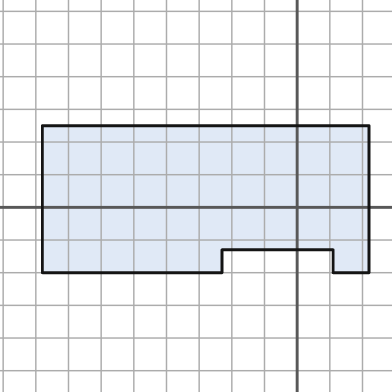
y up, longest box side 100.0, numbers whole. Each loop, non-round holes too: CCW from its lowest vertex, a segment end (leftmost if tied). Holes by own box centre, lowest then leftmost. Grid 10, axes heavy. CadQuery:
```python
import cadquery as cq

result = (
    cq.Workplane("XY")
    .moveTo(-78.0, -20.0)
    .lineTo(-23.0, -20.0)
    .lineTo(-23.0, -13.0)
    .lineTo(11.0, -13.0)
    .lineTo(11.0, -20.0)
    .lineTo(22.0, -20.0)
    .lineTo(22.0, 25.0)
    .lineTo(-78.0, 25.0)
    .close()
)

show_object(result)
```